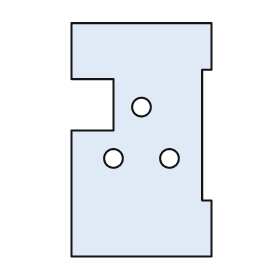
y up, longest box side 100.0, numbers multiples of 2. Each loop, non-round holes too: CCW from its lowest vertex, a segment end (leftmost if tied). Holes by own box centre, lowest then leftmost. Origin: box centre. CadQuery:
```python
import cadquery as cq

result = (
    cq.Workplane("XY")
    .moveTo(-30.0, -50.0)
    .lineTo(30.0, -50.0)
    .lineTo(30.0, -26.0)
    .lineTo(26.0, -26.0)
    .lineTo(26.0, 30.0)
    .lineTo(30.0, 30.0)
    .lineTo(30.0, 50.0)
    .lineTo(-30.0, 50.0)
    .lineTo(-30.0, 26.0)
    .lineTo(-12.0, 26.0)
    .lineTo(-12.0, 4.0)
    .lineTo(-30.0, 4.0)
    .close()
    .moveTo(-12.0, -8.0)
    .circle(4.0)
    .moveTo(12.0, -8.0)
    .circle(4.0)
    .moveTo(0.0, 14.0)
    .circle(4.0)
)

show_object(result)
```